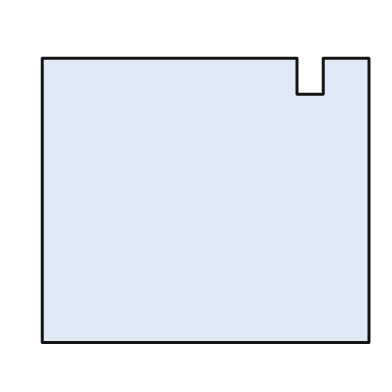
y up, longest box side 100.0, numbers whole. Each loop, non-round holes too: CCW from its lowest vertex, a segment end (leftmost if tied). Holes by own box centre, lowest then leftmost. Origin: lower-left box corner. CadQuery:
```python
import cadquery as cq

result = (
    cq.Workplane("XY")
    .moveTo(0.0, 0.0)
    .lineTo(100.0, 0.0)
    .lineTo(100.0, 87.0)
    .lineTo(86.0, 87.0)
    .lineTo(86.0, 76.0)
    .lineTo(78.0, 76.0)
    .lineTo(78.0, 87.0)
    .lineTo(0.0, 87.0)
    .close()
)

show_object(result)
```